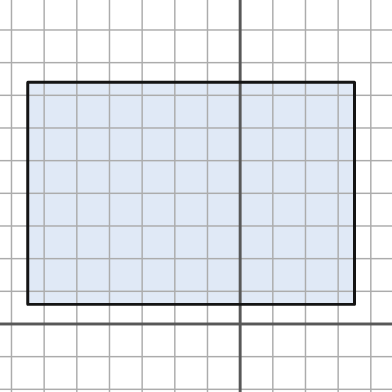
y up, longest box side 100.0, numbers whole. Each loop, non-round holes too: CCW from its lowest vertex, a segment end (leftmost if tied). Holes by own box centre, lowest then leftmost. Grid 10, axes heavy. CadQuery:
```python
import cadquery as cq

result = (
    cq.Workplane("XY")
    .moveTo(-65.0, 6.0)
    .lineTo(35.0, 6.0)
    .lineTo(35.0, 74.0)
    .lineTo(-65.0, 74.0)
    .close()
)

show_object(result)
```